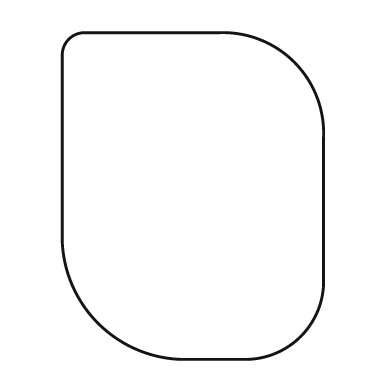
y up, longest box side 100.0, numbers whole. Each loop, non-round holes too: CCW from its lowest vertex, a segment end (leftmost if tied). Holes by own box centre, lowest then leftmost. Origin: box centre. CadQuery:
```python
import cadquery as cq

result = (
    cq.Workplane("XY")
    .moveTo(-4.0, -50.0)
    .lineTo(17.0, -50.0)
    .threePointArc((33.0, -43.0), (40.0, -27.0))
    .lineTo(40.0, 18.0)
    .threePointArc((31.0, 41.0), (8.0, 50.0))
    .lineTo(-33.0, 50.0)
    .threePointArc((-38.0, 48.0), (-40.0, 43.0))
    .lineTo(-40.0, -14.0)
    .threePointArc((-29.0, -39.0), (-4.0, -50.0))
    .close()
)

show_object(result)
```